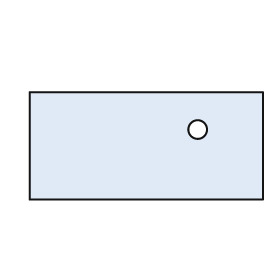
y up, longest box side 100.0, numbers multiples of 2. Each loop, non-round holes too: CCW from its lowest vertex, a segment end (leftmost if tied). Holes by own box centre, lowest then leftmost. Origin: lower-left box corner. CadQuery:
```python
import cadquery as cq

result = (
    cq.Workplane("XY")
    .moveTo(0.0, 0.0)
    .lineTo(100.0, 0.0)
    .lineTo(100.0, 46.0)
    .lineTo(0.0, 46.0)
    .close()
    .moveTo(72.0, 30.0)
    .circle(4.0)
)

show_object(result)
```